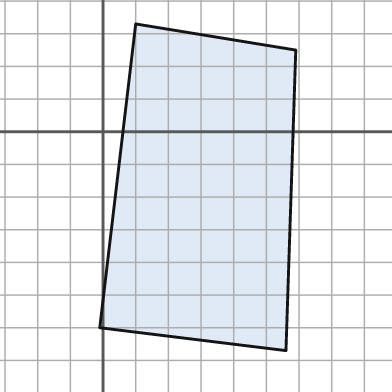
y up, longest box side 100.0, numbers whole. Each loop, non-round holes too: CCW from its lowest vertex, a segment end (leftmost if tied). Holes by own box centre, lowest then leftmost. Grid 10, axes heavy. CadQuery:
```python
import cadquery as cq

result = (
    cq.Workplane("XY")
    .moveTo(56.0, -67.0)
    .lineTo(59.0, 25.0)
    .lineTo(10.0, 33.0)
    .lineTo(-1.0, -60.0)
    .close()
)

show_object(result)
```